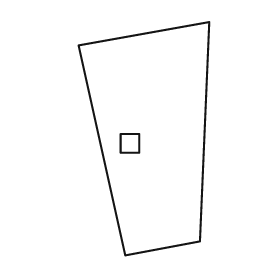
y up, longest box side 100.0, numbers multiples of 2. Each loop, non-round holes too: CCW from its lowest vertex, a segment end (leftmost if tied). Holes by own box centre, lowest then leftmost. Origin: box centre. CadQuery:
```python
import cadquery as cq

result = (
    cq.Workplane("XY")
    .moveTo(-8.0, -50.0)
    .lineTo(24.0, -44.0)
    .lineTo(28.0, 50.0)
    .lineTo(-28.0, 40.0)
    .close()
    .moveTo(-10.0, -6.0)
    .lineTo(-2.0, -6.0)
    .lineTo(-2.0, 2.0)
    .lineTo(-10.0, 2.0)
    .close()
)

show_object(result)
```